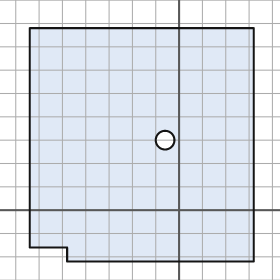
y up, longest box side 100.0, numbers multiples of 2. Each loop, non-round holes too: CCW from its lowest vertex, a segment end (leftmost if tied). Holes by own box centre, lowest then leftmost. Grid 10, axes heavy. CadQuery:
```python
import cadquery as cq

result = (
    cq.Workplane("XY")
    .moveTo(-48.0, -22.0)
    .lineTo(32.0, -22.0)
    .lineTo(32.0, 78.0)
    .lineTo(-64.0, 78.0)
    .lineTo(-64.0, -16.0)
    .lineTo(-48.0, -16.0)
    .close()
    .moveTo(-6.0, 30.0)
    .circle(4.0)
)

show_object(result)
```